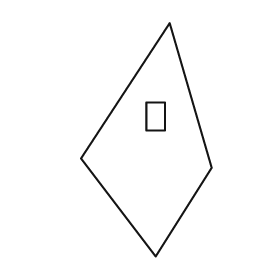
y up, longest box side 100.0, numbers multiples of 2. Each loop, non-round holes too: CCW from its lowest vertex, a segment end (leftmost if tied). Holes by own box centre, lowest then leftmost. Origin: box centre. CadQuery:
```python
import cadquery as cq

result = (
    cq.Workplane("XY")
    .moveTo(4.0, -50.0)
    .lineTo(28.0, -12.0)
    .lineTo(10.0, 50.0)
    .lineTo(-28.0, -8.0)
    .close()
    .moveTo(0.0, 4.0)
    .lineTo(8.0, 4.0)
    .lineTo(8.0, 16.0)
    .lineTo(0.0, 16.0)
    .close()
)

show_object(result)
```